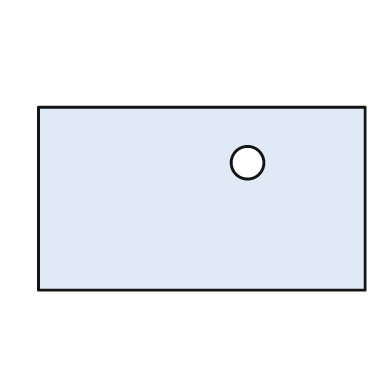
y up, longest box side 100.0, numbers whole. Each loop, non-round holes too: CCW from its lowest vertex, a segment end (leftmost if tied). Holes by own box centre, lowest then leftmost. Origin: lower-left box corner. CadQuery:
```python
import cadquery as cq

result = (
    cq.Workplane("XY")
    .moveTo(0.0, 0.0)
    .lineTo(100.0, 0.0)
    .lineTo(100.0, 56.0)
    .lineTo(0.0, 56.0)
    .close()
    .moveTo(64.0, 39.0)
    .circle(5.0)
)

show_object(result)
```